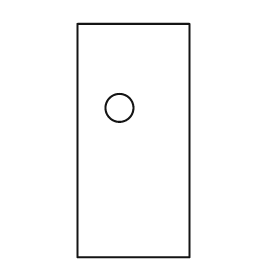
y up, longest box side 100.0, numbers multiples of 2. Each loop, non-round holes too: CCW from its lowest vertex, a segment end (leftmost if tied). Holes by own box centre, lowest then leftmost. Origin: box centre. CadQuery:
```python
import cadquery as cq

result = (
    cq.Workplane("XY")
    .moveTo(-24.0, -50.0)
    .lineTo(24.0, -50.0)
    .lineTo(24.0, 50.0)
    .lineTo(-24.0, 50.0)
    .close()
    .moveTo(-6.0, 14.0)
    .circle(6.0)
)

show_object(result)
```